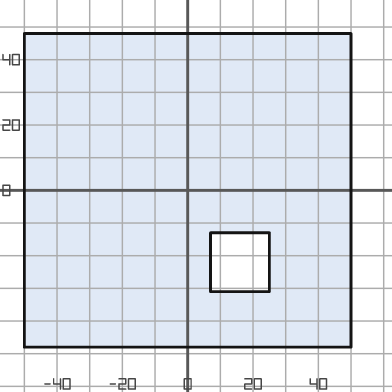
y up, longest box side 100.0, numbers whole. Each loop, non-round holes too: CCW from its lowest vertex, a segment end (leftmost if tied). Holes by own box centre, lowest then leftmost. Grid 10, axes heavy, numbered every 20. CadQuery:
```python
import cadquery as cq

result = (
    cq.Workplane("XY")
    .moveTo(-50.0, -48.0)
    .lineTo(50.0, -48.0)
    .lineTo(50.0, 48.0)
    .lineTo(-50.0, 48.0)
    .close()
    .moveTo(7.0, -31.0)
    .lineTo(25.0, -31.0)
    .lineTo(25.0, -13.0)
    .lineTo(7.0, -13.0)
    .close()
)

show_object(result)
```